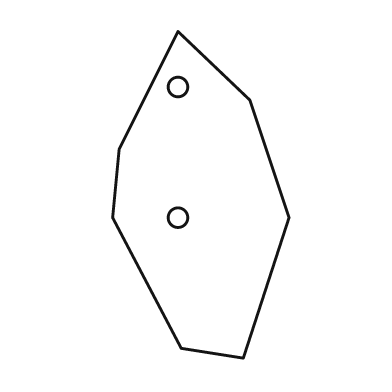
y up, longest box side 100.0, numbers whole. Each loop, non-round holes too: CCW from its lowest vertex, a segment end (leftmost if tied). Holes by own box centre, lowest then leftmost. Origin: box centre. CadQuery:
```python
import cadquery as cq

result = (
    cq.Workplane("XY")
    .moveTo(13.0, -50.0)
    .lineTo(27.0, -7.0)
    .lineTo(15.0, 29.0)
    .lineTo(-7.0, 50.0)
    .lineTo(-25.0, 14.0)
    .lineTo(-27.0, -7.0)
    .lineTo(-6.0, -47.0)
    .close()
    .moveTo(-7.0, -7.0)
    .circle(3.0)
    .moveTo(-7.0, 33.0)
    .circle(3.0)
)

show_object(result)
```